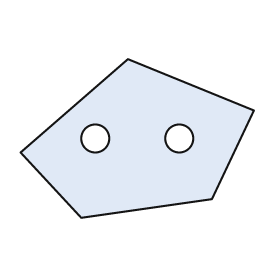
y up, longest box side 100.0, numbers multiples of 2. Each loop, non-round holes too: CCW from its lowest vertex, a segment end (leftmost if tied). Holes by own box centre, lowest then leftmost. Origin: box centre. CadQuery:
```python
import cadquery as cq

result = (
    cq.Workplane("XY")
    .moveTo(-24.0, -34.0)
    .lineTo(32.0, -26.0)
    .lineTo(50.0, 12.0)
    .lineTo(-4.0, 34.0)
    .lineTo(-50.0, -6.0)
    .close()
    .moveTo(-18.0, 0.0)
    .circle(6.0)
    .moveTo(18.0, 0.0)
    .circle(6.0)
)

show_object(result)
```